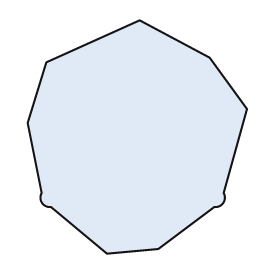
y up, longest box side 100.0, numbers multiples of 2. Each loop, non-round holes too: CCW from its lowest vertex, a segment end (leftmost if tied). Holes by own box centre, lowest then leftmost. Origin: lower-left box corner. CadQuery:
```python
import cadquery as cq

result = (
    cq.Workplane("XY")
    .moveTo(34.0, 0.0)
    .lineTo(56.0, 2.0)
    .lineTo(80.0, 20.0)
    .threePointArc((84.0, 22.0), (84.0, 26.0))
    .lineTo(94.0, 62.0)
    .lineTo(78.0, 84.0)
    .lineTo(48.0, 100.0)
    .lineTo(8.0, 82.0)
    .lineTo(0.0, 56.0)
    .lineTo(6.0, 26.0)
    .threePointArc((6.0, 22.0), (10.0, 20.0))
    .close()
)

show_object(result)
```